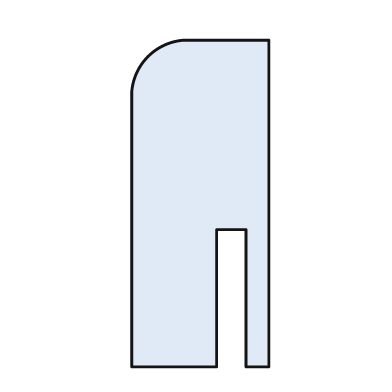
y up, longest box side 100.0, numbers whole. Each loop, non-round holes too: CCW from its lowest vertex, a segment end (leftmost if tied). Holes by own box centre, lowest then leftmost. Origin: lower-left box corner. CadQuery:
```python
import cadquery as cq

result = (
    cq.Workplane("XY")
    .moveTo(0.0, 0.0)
    .lineTo(26.0, 0.0)
    .lineTo(26.0, 42.0)
    .lineTo(35.0, 42.0)
    .lineTo(35.0, 0.0)
    .lineTo(42.0, 0.0)
    .lineTo(42.0, 100.0)
    .lineTo(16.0, 100.0)
    .threePointArc((5.0, 95.0), (0.0, 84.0))
    .close()
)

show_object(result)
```